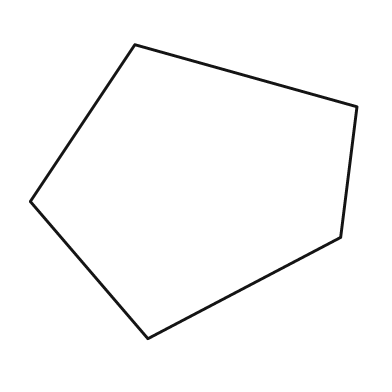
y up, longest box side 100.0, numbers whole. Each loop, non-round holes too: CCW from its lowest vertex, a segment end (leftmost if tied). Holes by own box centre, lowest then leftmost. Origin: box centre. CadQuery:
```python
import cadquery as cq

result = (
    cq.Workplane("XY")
    .moveTo(-14.0, -45.0)
    .lineTo(45.0, -14.0)
    .lineTo(50.0, 26.0)
    .lineTo(-18.0, 45.0)
    .lineTo(-50.0, -3.0)
    .close()
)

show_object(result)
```